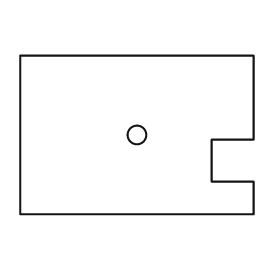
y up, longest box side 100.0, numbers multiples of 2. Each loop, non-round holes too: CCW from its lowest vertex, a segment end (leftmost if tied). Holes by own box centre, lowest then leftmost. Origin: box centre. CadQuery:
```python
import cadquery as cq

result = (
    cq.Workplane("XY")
    .moveTo(-50.0, -34.0)
    .lineTo(50.0, -34.0)
    .lineTo(50.0, -20.0)
    .lineTo(32.0, -20.0)
    .lineTo(32.0, -2.0)
    .lineTo(50.0, -2.0)
    .lineTo(50.0, 34.0)
    .lineTo(-50.0, 34.0)
    .close()
    .moveTo(0.0, 0.0)
    .circle(4.0)
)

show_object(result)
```